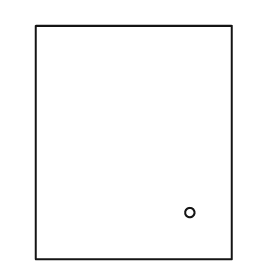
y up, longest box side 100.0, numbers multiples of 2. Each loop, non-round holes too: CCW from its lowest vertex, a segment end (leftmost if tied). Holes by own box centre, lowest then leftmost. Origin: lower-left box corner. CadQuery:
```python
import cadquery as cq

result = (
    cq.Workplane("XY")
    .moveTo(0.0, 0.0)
    .lineTo(84.0, 0.0)
    .lineTo(84.0, 100.0)
    .lineTo(0.0, 100.0)
    .close()
    .moveTo(66.0, 20.0)
    .circle(2.0)
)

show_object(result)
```